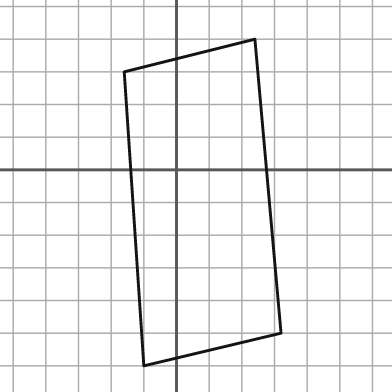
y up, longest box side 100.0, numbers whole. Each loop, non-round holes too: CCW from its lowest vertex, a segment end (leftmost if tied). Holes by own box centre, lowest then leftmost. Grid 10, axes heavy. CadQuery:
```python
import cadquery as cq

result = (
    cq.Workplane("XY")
    .moveTo(-10.0, -60.0)
    .lineTo(32.0, -50.0)
    .lineTo(24.0, 40.0)
    .lineTo(-16.0, 30.0)
    .close()
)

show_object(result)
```